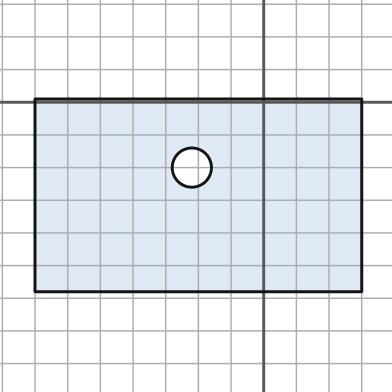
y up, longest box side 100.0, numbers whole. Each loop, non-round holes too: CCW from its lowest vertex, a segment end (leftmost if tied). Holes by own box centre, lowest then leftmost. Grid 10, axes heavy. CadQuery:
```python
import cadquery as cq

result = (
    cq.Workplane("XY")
    .moveTo(-70.0, -58.0)
    .lineTo(30.0, -58.0)
    .lineTo(30.0, 1.0)
    .lineTo(-70.0, 1.0)
    .close()
    .moveTo(-22.0, -20.0)
    .circle(6.0)
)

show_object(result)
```